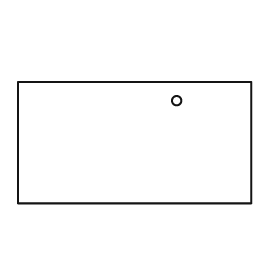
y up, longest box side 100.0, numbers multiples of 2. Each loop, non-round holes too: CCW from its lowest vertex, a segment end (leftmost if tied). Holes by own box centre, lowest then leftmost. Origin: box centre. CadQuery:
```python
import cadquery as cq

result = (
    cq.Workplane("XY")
    .moveTo(-50.0, -26.0)
    .lineTo(50.0, -26.0)
    .lineTo(50.0, 26.0)
    .lineTo(-50.0, 26.0)
    .close()
    .moveTo(18.0, 18.0)
    .circle(2.0)
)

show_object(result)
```